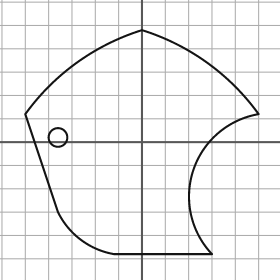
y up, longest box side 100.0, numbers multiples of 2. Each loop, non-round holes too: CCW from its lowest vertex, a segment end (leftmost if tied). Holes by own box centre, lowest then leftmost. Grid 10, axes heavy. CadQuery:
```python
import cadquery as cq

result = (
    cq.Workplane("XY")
    .moveTo(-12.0, -48.0)
    .lineTo(30.0, -48.0)
    .threePointArc((22.0, -12.0), (50.0, 12.0))
    .threePointArc((28.0, 34.0), (0.0, 48.0))
    .threePointArc((-28.0, 34.0), (-50.0, 12.0))
    .lineTo(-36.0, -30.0)
    .threePointArc((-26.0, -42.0), (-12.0, -48.0))
    .close()
    .moveTo(-36.0, 2.0)
    .circle(4.0)
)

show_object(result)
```